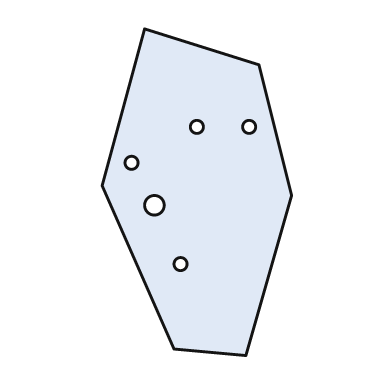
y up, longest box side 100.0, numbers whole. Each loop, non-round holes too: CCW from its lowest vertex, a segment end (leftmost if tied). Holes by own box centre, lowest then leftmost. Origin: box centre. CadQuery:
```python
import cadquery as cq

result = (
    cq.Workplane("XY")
    .moveTo(15.0, -50.0)
    .lineTo(29.0, -1.0)
    .lineTo(19.0, 39.0)
    .lineTo(-16.0, 50.0)
    .lineTo(-29.0, 2.0)
    .lineTo(-7.0, -48.0)
    .close()
    .moveTo(-5.0, -22.0)
    .circle(2.0)
    .moveTo(-13.0, -4.0)
    .circle(3.0)
    .moveTo(-20.0, 9.0)
    .circle(2.0)
    .moveTo(0.0, 20.0)
    .circle(2.0)
    .moveTo(16.0, 20.0)
    .circle(2.0)
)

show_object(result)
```